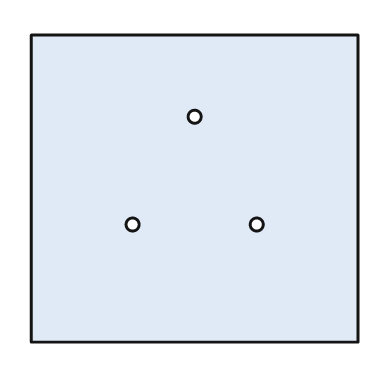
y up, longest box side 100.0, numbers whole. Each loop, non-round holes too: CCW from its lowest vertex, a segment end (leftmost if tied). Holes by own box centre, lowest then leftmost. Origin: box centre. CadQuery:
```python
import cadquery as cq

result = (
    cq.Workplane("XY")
    .moveTo(-50.0, -47.0)
    .lineTo(50.0, -47.0)
    .lineTo(50.0, 47.0)
    .lineTo(-50.0, 47.0)
    .close()
    .moveTo(-19.0, -11.0)
    .circle(2.0)
    .moveTo(19.0, -11.0)
    .circle(2.0)
    .moveTo(0.0, 22.0)
    .circle(2.0)
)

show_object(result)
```